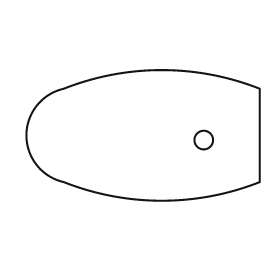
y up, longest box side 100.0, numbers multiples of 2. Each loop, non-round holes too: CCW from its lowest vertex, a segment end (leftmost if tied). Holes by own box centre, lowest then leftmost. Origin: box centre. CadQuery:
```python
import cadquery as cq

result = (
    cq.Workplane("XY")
    .moveTo(-34.0, -20.0)
    .threePointArc((8.0, -28.0), (50.0, -20.0))
    .lineTo(50.0, 20.0)
    .threePointArc((8.0, 28.0), (-34.0, 20.0))
    .threePointArc((-50.0, 0.0), (-34.0, -20.0))
    .close()
    .moveTo(26.0, -2.0)
    .circle(4.0)
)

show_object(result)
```